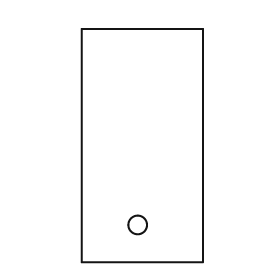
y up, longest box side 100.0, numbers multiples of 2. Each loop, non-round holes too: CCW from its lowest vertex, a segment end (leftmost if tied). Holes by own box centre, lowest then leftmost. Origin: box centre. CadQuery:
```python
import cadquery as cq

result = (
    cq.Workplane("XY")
    .moveTo(-26.0, -50.0)
    .lineTo(26.0, -50.0)
    .lineTo(26.0, 50.0)
    .lineTo(-26.0, 50.0)
    .close()
    .moveTo(-2.0, -34.0)
    .circle(4.0)
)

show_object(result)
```